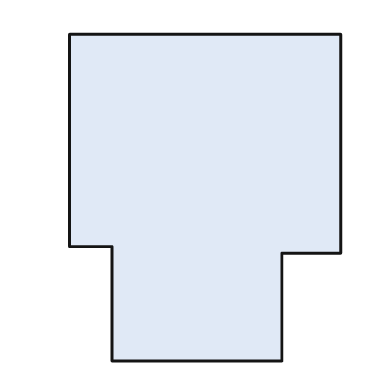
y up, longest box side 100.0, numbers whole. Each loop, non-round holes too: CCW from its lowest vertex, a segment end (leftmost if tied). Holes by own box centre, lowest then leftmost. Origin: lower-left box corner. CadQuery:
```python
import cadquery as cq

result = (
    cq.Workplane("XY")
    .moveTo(13.0, 0.0)
    .lineTo(65.0, 0.0)
    .lineTo(65.0, 33.0)
    .lineTo(83.0, 33.0)
    .lineTo(83.0, 100.0)
    .lineTo(0.0, 100.0)
    .lineTo(0.0, 35.0)
    .lineTo(13.0, 35.0)
    .close()
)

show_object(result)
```